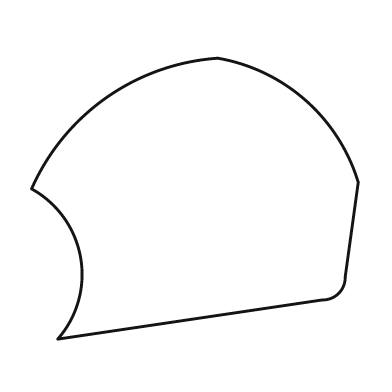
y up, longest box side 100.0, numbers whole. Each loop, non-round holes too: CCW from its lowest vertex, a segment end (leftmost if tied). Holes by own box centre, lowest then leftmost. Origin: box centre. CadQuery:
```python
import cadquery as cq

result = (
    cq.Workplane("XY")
    .moveTo(-42.0, -43.0)
    .lineTo(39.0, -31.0)
    .threePointArc((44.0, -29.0), (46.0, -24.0))
    .lineTo(50.0, 5.0)
    .threePointArc((34.0, 30.0), (7.0, 43.0))
    .threePointArc((-27.0, 31.0), (-50.0, 3.0))
    .threePointArc((-35.0, -18.0), (-42.0, -43.0))
    .close()
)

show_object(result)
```